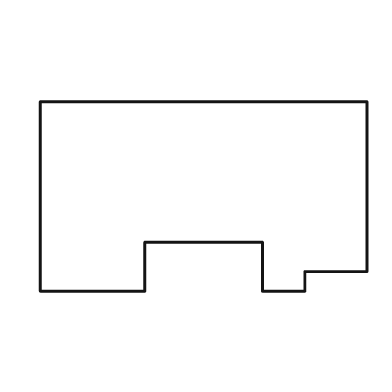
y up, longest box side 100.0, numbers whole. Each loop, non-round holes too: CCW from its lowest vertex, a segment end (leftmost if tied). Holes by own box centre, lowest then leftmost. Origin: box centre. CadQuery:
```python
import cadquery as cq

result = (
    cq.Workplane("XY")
    .moveTo(-50.0, -29.0)
    .lineTo(-18.0, -29.0)
    .lineTo(-18.0, -14.0)
    .lineTo(18.0, -14.0)
    .lineTo(18.0, -29.0)
    .lineTo(31.0, -29.0)
    .lineTo(31.0, -23.0)
    .lineTo(50.0, -23.0)
    .lineTo(50.0, 29.0)
    .lineTo(-50.0, 29.0)
    .close()
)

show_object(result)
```